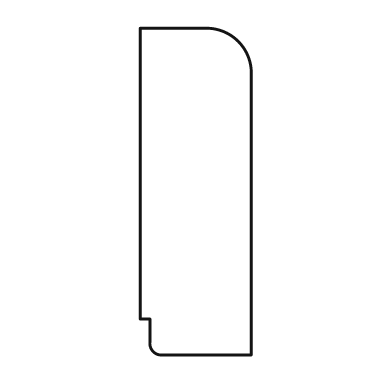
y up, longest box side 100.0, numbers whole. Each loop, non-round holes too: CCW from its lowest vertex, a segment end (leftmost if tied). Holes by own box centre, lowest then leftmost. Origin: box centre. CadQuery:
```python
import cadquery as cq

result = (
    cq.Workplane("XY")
    .moveTo(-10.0, -50.0)
    .lineTo(17.0, -50.0)
    .lineTo(17.0, 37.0)
    .threePointArc((13.0, 46.0), (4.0, 50.0))
    .lineTo(-17.0, 50.0)
    .lineTo(-17.0, -39.0)
    .lineTo(-14.0, -39.0)
    .lineTo(-14.0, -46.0)
    .threePointArc((-13.0, -49.0), (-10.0, -50.0))
    .close()
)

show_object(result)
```